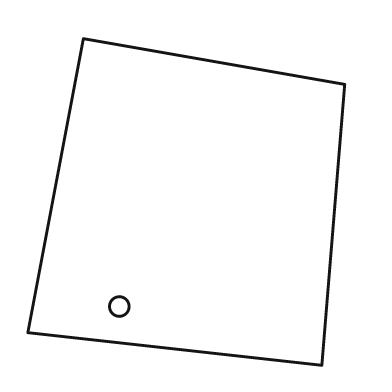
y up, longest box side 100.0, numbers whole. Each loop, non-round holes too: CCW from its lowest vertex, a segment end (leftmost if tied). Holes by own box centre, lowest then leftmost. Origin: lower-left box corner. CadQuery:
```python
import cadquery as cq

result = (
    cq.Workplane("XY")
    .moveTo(90.0, 0.0)
    .lineTo(97.0, 86.0)
    .lineTo(17.0, 100.0)
    .lineTo(0.0, 10.0)
    .close()
    .moveTo(28.0, 18.0)
    .circle(3.0)
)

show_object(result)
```